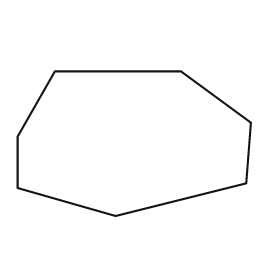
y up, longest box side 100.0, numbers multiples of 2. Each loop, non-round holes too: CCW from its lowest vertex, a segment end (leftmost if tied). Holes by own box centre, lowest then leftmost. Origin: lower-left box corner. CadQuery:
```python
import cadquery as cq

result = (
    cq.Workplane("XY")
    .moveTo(42.0, 0.0)
    .lineTo(98.0, 14.0)
    .lineTo(100.0, 40.0)
    .lineTo(70.0, 62.0)
    .lineTo(16.0, 62.0)
    .lineTo(0.0, 34.0)
    .lineTo(0.0, 12.0)
    .close()
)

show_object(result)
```